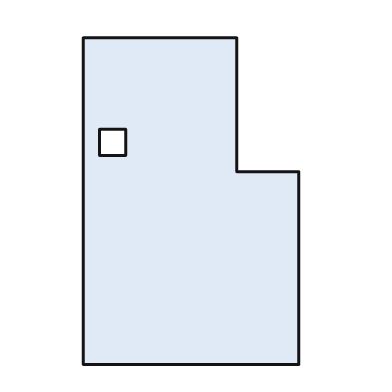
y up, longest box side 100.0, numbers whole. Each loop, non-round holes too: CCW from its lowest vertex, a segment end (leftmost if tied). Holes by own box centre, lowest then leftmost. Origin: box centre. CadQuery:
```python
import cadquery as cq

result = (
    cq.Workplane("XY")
    .moveTo(-33.0, -50.0)
    .lineTo(33.0, -50.0)
    .lineTo(33.0, 9.0)
    .lineTo(14.0, 9.0)
    .lineTo(14.0, 50.0)
    .lineTo(-33.0, 50.0)
    .close()
    .moveTo(-28.0, 14.0)
    .lineTo(-20.0, 14.0)
    .lineTo(-20.0, 22.0)
    .lineTo(-28.0, 22.0)
    .close()
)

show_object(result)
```